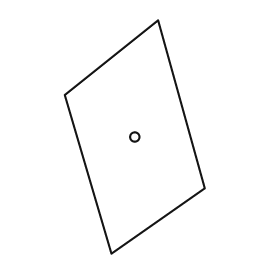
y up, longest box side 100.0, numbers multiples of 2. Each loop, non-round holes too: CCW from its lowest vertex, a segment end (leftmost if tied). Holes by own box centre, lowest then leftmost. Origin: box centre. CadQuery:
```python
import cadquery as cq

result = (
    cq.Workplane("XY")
    .moveTo(-10.0, -50.0)
    .lineTo(30.0, -22.0)
    .lineTo(10.0, 50.0)
    .lineTo(-30.0, 18.0)
    .close()
    .moveTo(0.0, 0.0)
    .circle(2.0)
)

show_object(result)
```